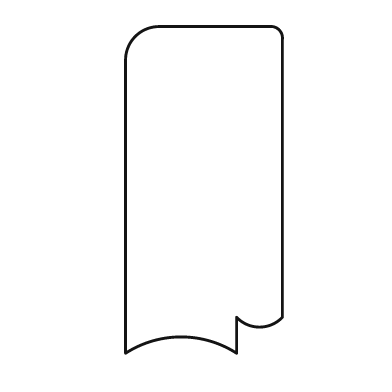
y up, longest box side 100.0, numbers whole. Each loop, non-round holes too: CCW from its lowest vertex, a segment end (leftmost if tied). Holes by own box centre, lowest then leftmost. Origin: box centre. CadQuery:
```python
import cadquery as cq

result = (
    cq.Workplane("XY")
    .moveTo(-24.0, -50.0)
    .threePointArc((-7.0, -45.0), (10.0, -50.0))
    .lineTo(10.0, -39.0)
    .threePointArc((17.0, -42.0), (24.0, -39.0))
    .lineTo(24.0, 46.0)
    .threePointArc((23.0, 49.0), (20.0, 50.0))
    .lineTo(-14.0, 50.0)
    .threePointArc((-21.0, 47.0), (-24.0, 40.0))
    .close()
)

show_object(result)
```